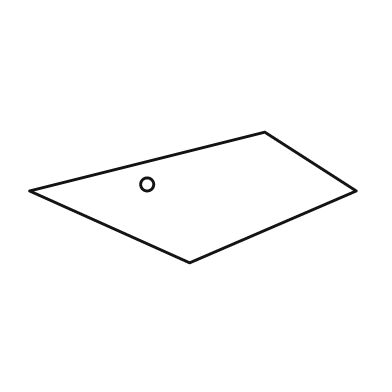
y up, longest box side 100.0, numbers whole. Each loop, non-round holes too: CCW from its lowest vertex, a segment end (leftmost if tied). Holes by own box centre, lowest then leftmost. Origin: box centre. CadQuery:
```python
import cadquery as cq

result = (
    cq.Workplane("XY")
    .moveTo(-1.0, -20.0)
    .lineTo(50.0, 2.0)
    .lineTo(22.0, 20.0)
    .lineTo(-50.0, 2.0)
    .close()
    .moveTo(-14.0, 4.0)
    .circle(2.0)
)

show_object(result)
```